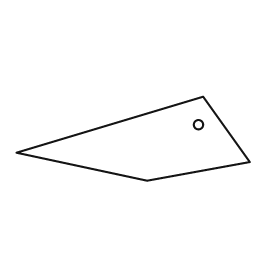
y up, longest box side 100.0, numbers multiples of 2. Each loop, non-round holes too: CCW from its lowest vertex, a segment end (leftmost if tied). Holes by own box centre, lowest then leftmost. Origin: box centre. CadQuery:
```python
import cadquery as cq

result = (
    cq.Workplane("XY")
    .moveTo(6.0, -18.0)
    .lineTo(50.0, -10.0)
    .lineTo(30.0, 18.0)
    .lineTo(-50.0, -6.0)
    .close()
    .moveTo(28.0, 6.0)
    .circle(2.0)
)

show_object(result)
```